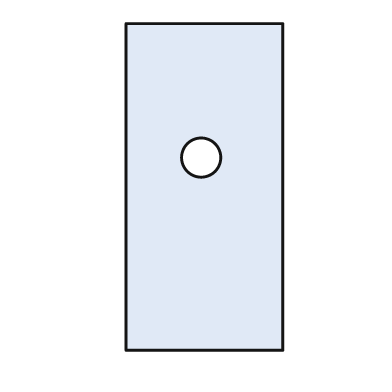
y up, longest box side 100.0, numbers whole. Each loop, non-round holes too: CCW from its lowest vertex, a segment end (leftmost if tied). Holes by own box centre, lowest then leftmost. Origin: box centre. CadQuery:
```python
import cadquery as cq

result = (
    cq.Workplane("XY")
    .moveTo(-24.0, -50.0)
    .lineTo(24.0, -50.0)
    .lineTo(24.0, 50.0)
    .lineTo(-24.0, 50.0)
    .close()
    .moveTo(-1.0, 9.0)
    .circle(6.0)
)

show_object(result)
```